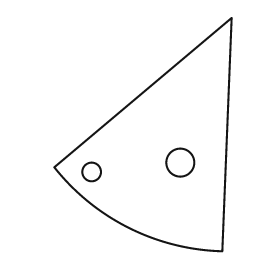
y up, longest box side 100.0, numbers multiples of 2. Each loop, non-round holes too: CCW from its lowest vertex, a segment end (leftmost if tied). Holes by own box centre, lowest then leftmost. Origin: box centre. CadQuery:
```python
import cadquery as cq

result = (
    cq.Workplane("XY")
    .moveTo(34.0, -50.0)
    .lineTo(38.0, 50.0)
    .lineTo(-38.0, -14.0)
    .threePointArc((-6.0, -40.0), (34.0, -50.0))
    .close()
    .moveTo(-22.0, -16.0)
    .circle(4.0)
    .moveTo(16.0, -12.0)
    .circle(6.0)
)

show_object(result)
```